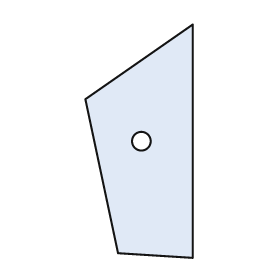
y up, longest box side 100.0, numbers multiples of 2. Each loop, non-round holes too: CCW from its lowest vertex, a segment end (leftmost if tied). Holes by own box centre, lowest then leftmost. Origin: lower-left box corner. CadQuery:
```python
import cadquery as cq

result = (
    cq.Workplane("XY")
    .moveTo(46.0, 0.0)
    .lineTo(46.0, 100.0)
    .lineTo(0.0, 68.0)
    .lineTo(14.0, 2.0)
    .close()
    .moveTo(24.0, 50.0)
    .circle(4.0)
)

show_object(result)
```